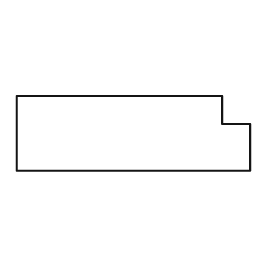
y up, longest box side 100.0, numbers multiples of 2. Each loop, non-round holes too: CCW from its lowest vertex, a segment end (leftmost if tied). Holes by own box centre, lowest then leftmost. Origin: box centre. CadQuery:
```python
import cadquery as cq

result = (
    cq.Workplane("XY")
    .moveTo(-50.0, -16.0)
    .lineTo(50.0, -16.0)
    .lineTo(50.0, 4.0)
    .lineTo(38.0, 4.0)
    .lineTo(38.0, 16.0)
    .lineTo(-50.0, 16.0)
    .close()
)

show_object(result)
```